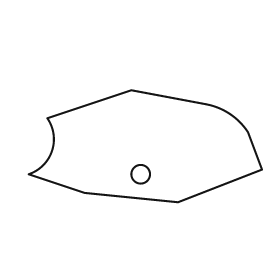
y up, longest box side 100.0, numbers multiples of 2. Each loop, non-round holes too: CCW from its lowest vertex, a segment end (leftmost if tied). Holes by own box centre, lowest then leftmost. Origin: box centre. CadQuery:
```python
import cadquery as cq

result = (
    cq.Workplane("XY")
    .moveTo(14.0, -24.0)
    .lineTo(50.0, -10.0)
    .lineTo(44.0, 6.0)
    .threePointArc((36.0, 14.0), (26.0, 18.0))
    .lineTo(-6.0, 24.0)
    .lineTo(-42.0, 12.0)
    .threePointArc((-40.0, -2.0), (-50.0, -12.0))
    .lineTo(-26.0, -20.0)
    .close()
    .moveTo(-2.0, -12.0)
    .circle(4.0)
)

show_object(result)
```